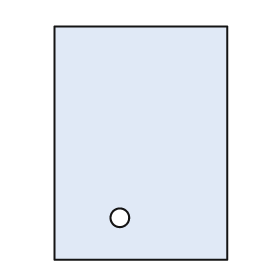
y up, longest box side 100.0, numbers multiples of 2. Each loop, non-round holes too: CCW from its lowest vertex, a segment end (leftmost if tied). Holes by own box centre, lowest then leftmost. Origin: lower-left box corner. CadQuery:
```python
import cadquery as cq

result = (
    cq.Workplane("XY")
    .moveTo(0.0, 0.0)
    .lineTo(74.0, 0.0)
    .lineTo(74.0, 100.0)
    .lineTo(0.0, 100.0)
    .close()
    .moveTo(28.0, 18.0)
    .circle(4.0)
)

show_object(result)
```